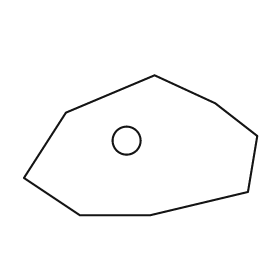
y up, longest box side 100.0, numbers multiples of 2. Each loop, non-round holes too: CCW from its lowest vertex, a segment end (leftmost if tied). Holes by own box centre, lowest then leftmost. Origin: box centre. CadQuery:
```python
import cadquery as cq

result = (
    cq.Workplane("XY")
    .moveTo(-26.0, -30.0)
    .lineTo(4.0, -30.0)
    .lineTo(46.0, -20.0)
    .lineTo(50.0, 4.0)
    .lineTo(32.0, 18.0)
    .lineTo(6.0, 30.0)
    .lineTo(-32.0, 14.0)
    .lineTo(-50.0, -14.0)
    .close()
    .moveTo(-6.0, 2.0)
    .circle(6.0)
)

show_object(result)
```